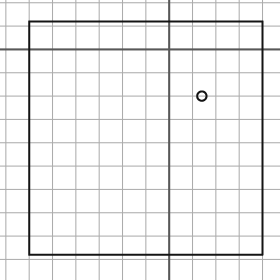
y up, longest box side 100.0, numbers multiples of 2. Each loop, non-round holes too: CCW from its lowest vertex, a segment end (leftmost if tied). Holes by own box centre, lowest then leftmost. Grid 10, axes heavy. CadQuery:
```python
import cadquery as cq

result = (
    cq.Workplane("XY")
    .moveTo(-60.0, -88.0)
    .lineTo(40.0, -88.0)
    .lineTo(40.0, 12.0)
    .lineTo(-60.0, 12.0)
    .close()
    .moveTo(14.0, -20.0)
    .circle(2.0)
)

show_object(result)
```